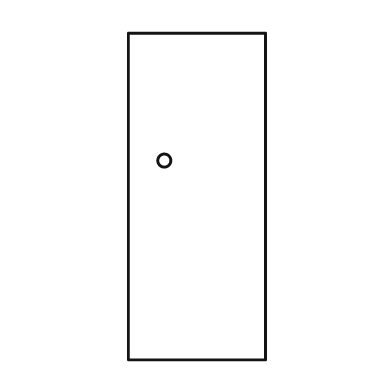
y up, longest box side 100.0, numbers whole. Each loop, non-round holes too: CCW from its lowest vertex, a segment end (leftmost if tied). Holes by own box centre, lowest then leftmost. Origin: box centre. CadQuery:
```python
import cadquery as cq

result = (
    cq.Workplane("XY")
    .moveTo(-21.0, -50.0)
    .lineTo(21.0, -50.0)
    .lineTo(21.0, 50.0)
    .lineTo(-21.0, 50.0)
    .close()
    .moveTo(-10.0, 11.0)
    .circle(2.0)
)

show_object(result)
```